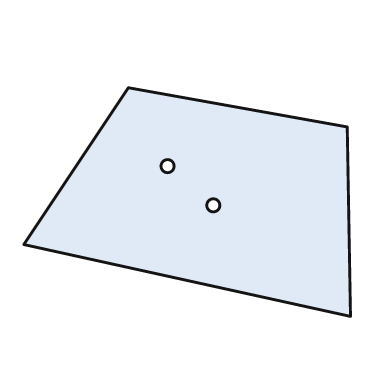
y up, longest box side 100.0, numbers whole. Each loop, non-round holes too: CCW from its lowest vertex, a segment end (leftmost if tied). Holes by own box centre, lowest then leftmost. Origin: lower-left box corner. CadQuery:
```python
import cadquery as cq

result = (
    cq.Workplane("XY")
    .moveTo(100.0, 0.0)
    .lineTo(99.0, 58.0)
    .lineTo(32.0, 70.0)
    .lineTo(0.0, 22.0)
    .close()
    .moveTo(58.0, 34.0)
    .circle(2.0)
    .moveTo(44.0, 46.0)
    .circle(2.0)
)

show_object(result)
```